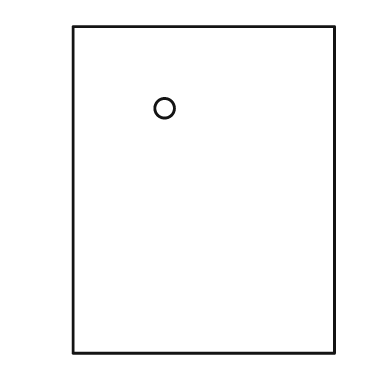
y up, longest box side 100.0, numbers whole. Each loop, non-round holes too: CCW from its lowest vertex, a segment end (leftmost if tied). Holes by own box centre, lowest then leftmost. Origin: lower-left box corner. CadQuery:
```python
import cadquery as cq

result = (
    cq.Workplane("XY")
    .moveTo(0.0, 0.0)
    .lineTo(80.0, 0.0)
    .lineTo(80.0, 100.0)
    .lineTo(0.0, 100.0)
    .close()
    .moveTo(28.0, 75.0)
    .circle(3.0)
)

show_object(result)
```